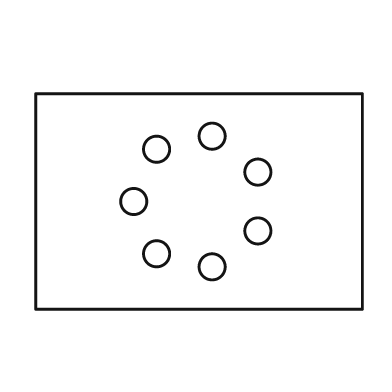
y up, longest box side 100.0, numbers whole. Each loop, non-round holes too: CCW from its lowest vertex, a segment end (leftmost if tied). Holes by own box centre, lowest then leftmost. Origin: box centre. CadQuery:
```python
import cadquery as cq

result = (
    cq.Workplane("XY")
    .moveTo(-50.0, -33.0)
    .lineTo(50.0, -33.0)
    .lineTo(50.0, 33.0)
    .lineTo(-50.0, 33.0)
    .close()
    .moveTo(4.0, -20.0)
    .circle(4.0)
    .moveTo(-13.0, -16.0)
    .circle(4.0)
    .moveTo(18.0, -9.0)
    .circle(4.0)
    .moveTo(-20.0, 0.0)
    .circle(4.0)
    .moveTo(18.0, 9.0)
    .circle(4.0)
    .moveTo(-13.0, 16.0)
    .circle(4.0)
    .moveTo(4.0, 20.0)
    .circle(4.0)
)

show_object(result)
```